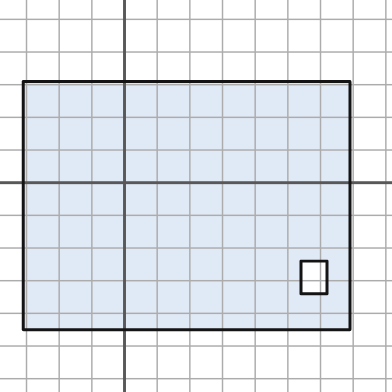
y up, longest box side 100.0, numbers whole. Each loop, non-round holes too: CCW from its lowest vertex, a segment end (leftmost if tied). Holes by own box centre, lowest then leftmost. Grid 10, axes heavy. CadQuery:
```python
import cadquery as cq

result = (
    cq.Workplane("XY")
    .moveTo(-31.0, -45.0)
    .lineTo(69.0, -45.0)
    .lineTo(69.0, 31.0)
    .lineTo(-31.0, 31.0)
    .close()
    .moveTo(54.0, -34.0)
    .lineTo(62.0, -34.0)
    .lineTo(62.0, -24.0)
    .lineTo(54.0, -24.0)
    .close()
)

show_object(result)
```